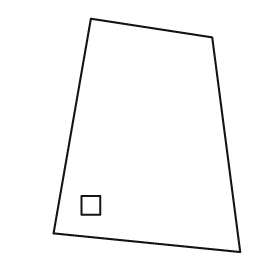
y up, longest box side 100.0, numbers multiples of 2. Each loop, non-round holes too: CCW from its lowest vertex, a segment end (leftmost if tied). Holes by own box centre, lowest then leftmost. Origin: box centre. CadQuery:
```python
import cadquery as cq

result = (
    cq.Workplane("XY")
    .moveTo(40.0, -50.0)
    .lineTo(28.0, 42.0)
    .lineTo(-24.0, 50.0)
    .lineTo(-40.0, -42.0)
    .close()
    .moveTo(-28.0, -34.0)
    .lineTo(-20.0, -34.0)
    .lineTo(-20.0, -26.0)
    .lineTo(-28.0, -26.0)
    .close()
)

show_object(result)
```